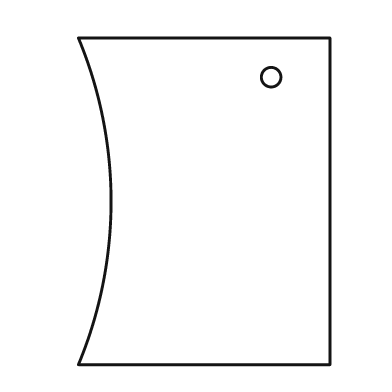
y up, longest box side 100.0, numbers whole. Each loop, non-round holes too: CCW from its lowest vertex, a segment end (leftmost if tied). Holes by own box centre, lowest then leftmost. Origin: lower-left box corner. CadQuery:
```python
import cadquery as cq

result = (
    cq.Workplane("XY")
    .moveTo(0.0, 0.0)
    .lineTo(77.0, 0.0)
    .lineTo(77.0, 100.0)
    .lineTo(0.0, 100.0)
    .threePointArc((10.0, 50.0), (0.0, 0.0))
    .close()
    .moveTo(59.0, 88.0)
    .circle(3.0)
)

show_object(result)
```